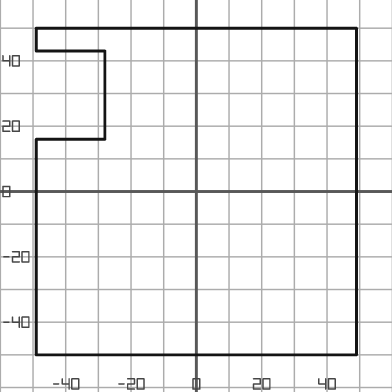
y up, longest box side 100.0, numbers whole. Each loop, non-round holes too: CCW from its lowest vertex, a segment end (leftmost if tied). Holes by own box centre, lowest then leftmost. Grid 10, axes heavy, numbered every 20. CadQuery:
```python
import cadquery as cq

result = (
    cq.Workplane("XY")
    .moveTo(-49.0, -50.0)
    .lineTo(49.0, -50.0)
    .lineTo(49.0, 50.0)
    .lineTo(-49.0, 50.0)
    .lineTo(-49.0, 43.0)
    .lineTo(-28.0, 43.0)
    .lineTo(-28.0, 16.0)
    .lineTo(-49.0, 16.0)
    .close()
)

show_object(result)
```